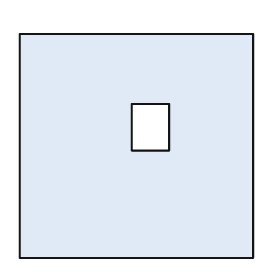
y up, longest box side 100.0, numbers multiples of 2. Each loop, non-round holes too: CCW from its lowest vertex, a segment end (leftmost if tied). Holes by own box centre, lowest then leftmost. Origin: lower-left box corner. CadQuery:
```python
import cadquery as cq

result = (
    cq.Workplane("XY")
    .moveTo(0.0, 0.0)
    .lineTo(100.0, 0.0)
    .lineTo(100.0, 96.0)
    .lineTo(0.0, 96.0)
    .close()
    .moveTo(48.0, 46.0)
    .lineTo(64.0, 46.0)
    .lineTo(64.0, 66.0)
    .lineTo(48.0, 66.0)
    .close()
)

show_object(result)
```